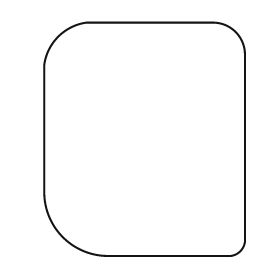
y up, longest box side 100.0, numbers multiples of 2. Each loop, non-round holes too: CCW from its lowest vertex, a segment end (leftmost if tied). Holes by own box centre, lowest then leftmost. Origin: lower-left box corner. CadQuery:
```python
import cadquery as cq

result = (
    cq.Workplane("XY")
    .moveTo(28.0, 0.0)
    .lineTo(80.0, 0.0)
    .threePointArc((84.0, 2.0), (86.0, 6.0))
    .lineTo(86.0, 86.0)
    .threePointArc((82.0, 96.0), (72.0, 100.0))
    .lineTo(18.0, 100.0)
    .threePointArc((6.0, 94.0), (0.0, 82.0))
    .lineTo(0.0, 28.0)
    .threePointArc((8.0, 8.0), (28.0, 0.0))
    .close()
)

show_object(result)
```